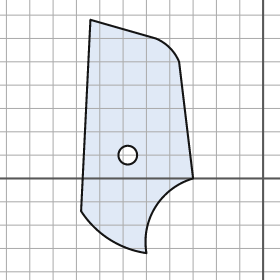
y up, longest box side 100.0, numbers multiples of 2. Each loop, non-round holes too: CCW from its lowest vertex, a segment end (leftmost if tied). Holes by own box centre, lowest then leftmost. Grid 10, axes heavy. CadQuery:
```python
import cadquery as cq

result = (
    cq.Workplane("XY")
    .moveTo(-50.0, -32.0)
    .threePointArc((-46.0, -12.0), (-30.0, 0.0))
    .lineTo(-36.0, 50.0)
    .threePointArc((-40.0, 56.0), (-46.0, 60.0))
    .lineTo(-74.0, 68.0)
    .lineTo(-78.0, -14.0)
    .threePointArc((-66.0, -26.0), (-50.0, -32.0))
    .close()
    .moveTo(-58.0, 10.0)
    .circle(4.0)
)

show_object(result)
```